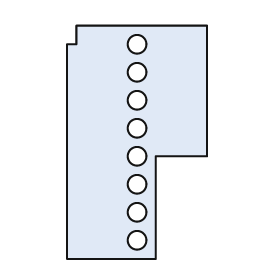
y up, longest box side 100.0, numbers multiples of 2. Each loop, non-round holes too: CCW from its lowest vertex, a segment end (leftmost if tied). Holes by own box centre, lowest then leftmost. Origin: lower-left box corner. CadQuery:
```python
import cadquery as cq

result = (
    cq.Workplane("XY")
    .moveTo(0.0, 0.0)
    .lineTo(38.0, 0.0)
    .lineTo(38.0, 44.0)
    .lineTo(60.0, 44.0)
    .lineTo(60.0, 100.0)
    .lineTo(4.0, 100.0)
    .lineTo(4.0, 92.0)
    .lineTo(0.0, 92.0)
    .close()
    .moveTo(30.0, 8.0)
    .circle(4.0)
    .moveTo(30.0, 20.0)
    .circle(4.0)
    .moveTo(30.0, 32.0)
    .circle(4.0)
    .moveTo(30.0, 44.0)
    .circle(4.0)
    .moveTo(30.0, 56.0)
    .circle(4.0)
    .moveTo(30.0, 68.0)
    .circle(4.0)
    .moveTo(30.0, 80.0)
    .circle(4.0)
    .moveTo(30.0, 92.0)
    .circle(4.0)
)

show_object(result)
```